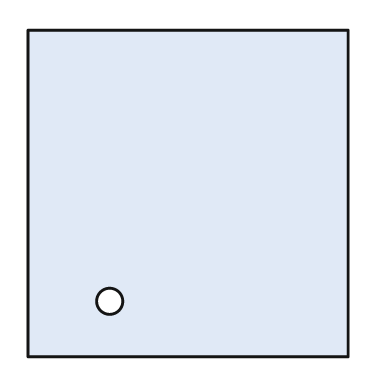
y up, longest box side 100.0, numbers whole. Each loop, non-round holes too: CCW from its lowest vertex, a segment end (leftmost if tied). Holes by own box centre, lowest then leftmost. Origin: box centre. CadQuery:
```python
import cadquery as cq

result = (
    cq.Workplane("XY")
    .moveTo(-49.0, -50.0)
    .lineTo(49.0, -50.0)
    .lineTo(49.0, 50.0)
    .lineTo(-49.0, 50.0)
    .close()
    .moveTo(-24.0, -33.0)
    .circle(4.0)
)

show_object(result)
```